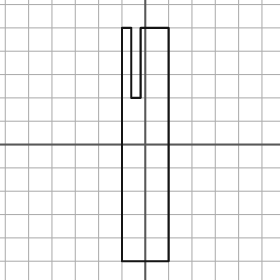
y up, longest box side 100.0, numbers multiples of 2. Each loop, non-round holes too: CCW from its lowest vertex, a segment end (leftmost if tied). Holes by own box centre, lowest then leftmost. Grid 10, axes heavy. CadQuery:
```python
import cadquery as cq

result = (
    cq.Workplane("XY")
    .moveTo(-10.0, -50.0)
    .lineTo(10.0, -50.0)
    .lineTo(10.0, 50.0)
    .lineTo(-2.0, 50.0)
    .lineTo(-2.0, 20.0)
    .lineTo(-6.0, 20.0)
    .lineTo(-6.0, 50.0)
    .lineTo(-10.0, 50.0)
    .close()
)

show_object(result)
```